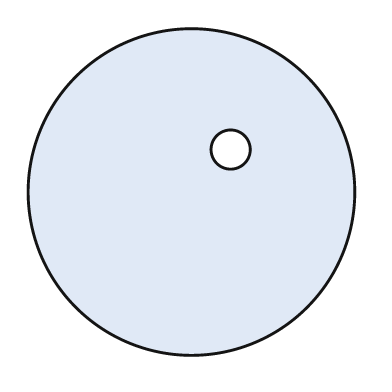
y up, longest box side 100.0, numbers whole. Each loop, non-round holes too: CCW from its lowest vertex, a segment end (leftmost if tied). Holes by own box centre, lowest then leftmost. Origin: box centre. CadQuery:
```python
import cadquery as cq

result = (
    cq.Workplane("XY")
    .moveTo(0.0, 0.0)
    .circle(50.0)
    .moveTo(12.0, 13.0)
    .circle(6.0)
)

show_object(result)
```